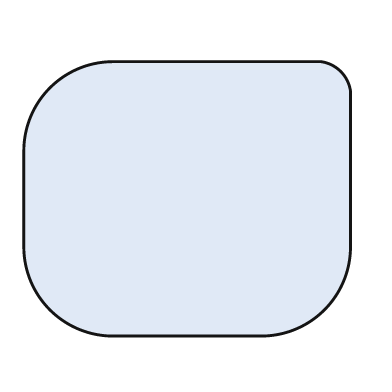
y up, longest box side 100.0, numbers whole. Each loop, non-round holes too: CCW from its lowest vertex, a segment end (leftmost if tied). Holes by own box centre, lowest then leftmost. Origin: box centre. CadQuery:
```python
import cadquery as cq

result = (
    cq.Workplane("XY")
    .moveTo(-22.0, -42.0)
    .lineTo(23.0, -42.0)
    .threePointArc((42.0, -34.0), (50.0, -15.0))
    .lineTo(50.0, 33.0)
    .threePointArc((47.0, 39.0), (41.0, 42.0))
    .lineTo(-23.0, 42.0)
    .threePointArc((-42.0, 34.0), (-50.0, 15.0))
    .lineTo(-50.0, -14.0)
    .threePointArc((-42.0, -34.0), (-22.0, -42.0))
    .close()
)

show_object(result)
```